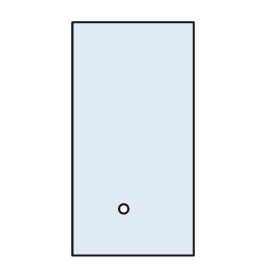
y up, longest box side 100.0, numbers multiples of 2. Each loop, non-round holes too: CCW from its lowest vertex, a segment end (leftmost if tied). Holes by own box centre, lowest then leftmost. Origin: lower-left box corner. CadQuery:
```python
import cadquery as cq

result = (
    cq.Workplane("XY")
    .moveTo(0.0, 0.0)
    .lineTo(52.0, 0.0)
    .lineTo(52.0, 100.0)
    .lineTo(0.0, 100.0)
    .close()
    .moveTo(22.0, 20.0)
    .circle(2.0)
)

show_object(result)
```